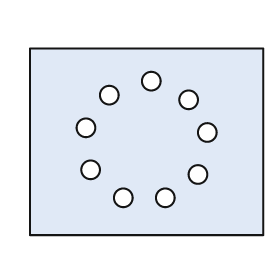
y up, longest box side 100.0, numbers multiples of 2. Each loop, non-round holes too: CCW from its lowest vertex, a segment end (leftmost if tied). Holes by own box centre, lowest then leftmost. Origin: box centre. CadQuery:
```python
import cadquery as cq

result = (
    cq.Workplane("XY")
    .moveTo(-50.0, -40.0)
    .lineTo(50.0, -40.0)
    .lineTo(50.0, 40.0)
    .lineTo(-50.0, 40.0)
    .close()
    .moveTo(-10.0, -24.0)
    .circle(4.0)
    .moveTo(8.0, -24.0)
    .circle(4.0)
    .moveTo(22.0, -14.0)
    .circle(4.0)
    .moveTo(-24.0, -12.0)
    .circle(4.0)
    .moveTo(26.0, 4.0)
    .circle(4.0)
    .moveTo(-26.0, 6.0)
    .circle(4.0)
    .moveTo(18.0, 18.0)
    .circle(4.0)
    .moveTo(-16.0, 20.0)
    .circle(4.0)
    .moveTo(2.0, 26.0)
    .circle(4.0)
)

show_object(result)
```